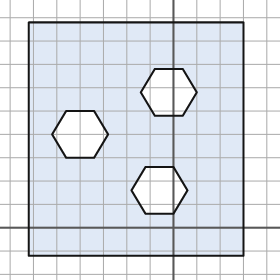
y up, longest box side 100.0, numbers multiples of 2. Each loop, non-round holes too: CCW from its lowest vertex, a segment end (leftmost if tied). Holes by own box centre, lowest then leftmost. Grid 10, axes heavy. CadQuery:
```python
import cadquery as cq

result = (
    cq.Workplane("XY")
    .moveTo(-62.0, -12.0)
    .lineTo(30.0, -12.0)
    .lineTo(30.0, 88.0)
    .lineTo(-62.0, 88.0)
    .close()
    .moveTo(-12.0, 6.0)
    .lineTo(0.0, 6.0)
    .lineTo(6.0, 16.0)
    .lineTo(0.0, 26.0)
    .lineTo(-12.0, 26.0)
    .lineTo(-18.0, 16.0)
    .close()
    .moveTo(-46.0, 30.0)
    .lineTo(-34.0, 30.0)
    .lineTo(-28.0, 40.0)
    .lineTo(-34.0, 50.0)
    .lineTo(-46.0, 50.0)
    .lineTo(-52.0, 40.0)
    .close()
    .moveTo(-8.0, 48.0)
    .lineTo(4.0, 48.0)
    .lineTo(10.0, 58.0)
    .lineTo(4.0, 68.0)
    .lineTo(-8.0, 68.0)
    .lineTo(-14.0, 58.0)
    .close()
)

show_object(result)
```